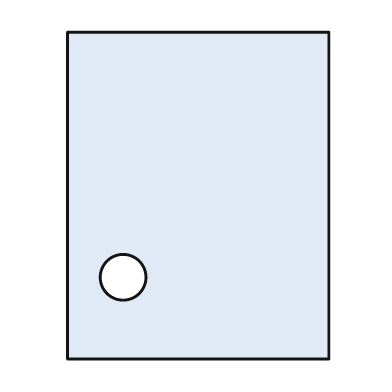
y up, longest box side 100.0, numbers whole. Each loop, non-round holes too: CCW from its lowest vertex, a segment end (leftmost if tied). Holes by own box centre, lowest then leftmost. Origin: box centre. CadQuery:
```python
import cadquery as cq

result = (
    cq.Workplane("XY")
    .moveTo(-40.0, -50.0)
    .lineTo(40.0, -50.0)
    .lineTo(40.0, 50.0)
    .lineTo(-40.0, 50.0)
    .close()
    .moveTo(-23.0, -25.0)
    .circle(7.0)
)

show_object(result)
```